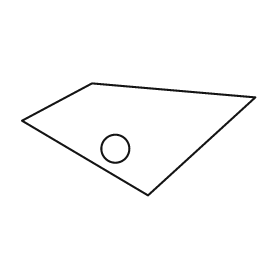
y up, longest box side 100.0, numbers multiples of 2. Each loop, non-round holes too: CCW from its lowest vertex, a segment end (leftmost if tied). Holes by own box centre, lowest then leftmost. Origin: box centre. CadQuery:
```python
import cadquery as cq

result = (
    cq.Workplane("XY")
    .moveTo(4.0, -24.0)
    .lineTo(50.0, 18.0)
    .lineTo(-20.0, 24.0)
    .lineTo(-50.0, 8.0)
    .close()
    .moveTo(-10.0, -4.0)
    .circle(6.0)
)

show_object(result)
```